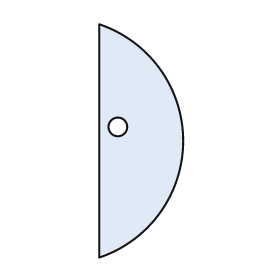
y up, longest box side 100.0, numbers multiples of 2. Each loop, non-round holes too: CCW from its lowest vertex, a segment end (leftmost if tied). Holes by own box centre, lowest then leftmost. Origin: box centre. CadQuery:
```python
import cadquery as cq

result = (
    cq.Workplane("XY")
    .moveTo(-18.0, -50.0)
    .threePointArc((18.0, 0.0), (-18.0, 50.0))
    .close()
    .moveTo(-10.0, 6.0)
    .circle(4.0)
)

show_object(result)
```